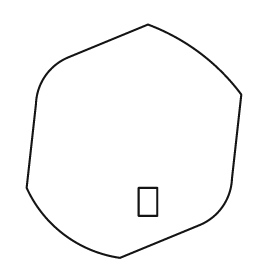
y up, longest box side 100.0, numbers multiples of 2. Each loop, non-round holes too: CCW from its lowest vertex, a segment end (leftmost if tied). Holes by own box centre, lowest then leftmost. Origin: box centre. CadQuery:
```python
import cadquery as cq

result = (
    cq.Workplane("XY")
    .moveTo(-6.0, -50.0)
    .lineTo(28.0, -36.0)
    .threePointArc((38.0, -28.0), (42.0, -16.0))
    .lineTo(46.0, 20.0)
    .threePointArc((28.0, 38.0), (6.0, 50.0))
    .lineTo(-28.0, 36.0)
    .threePointArc((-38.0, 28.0), (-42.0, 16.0))
    .lineTo(-46.0, -20.0)
    .threePointArc((-30.0, -40.0), (-6.0, -50.0))
    .close()
    .moveTo(2.0, -32.0)
    .lineTo(10.0, -32.0)
    .lineTo(10.0, -20.0)
    .lineTo(2.0, -20.0)
    .close()
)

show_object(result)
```